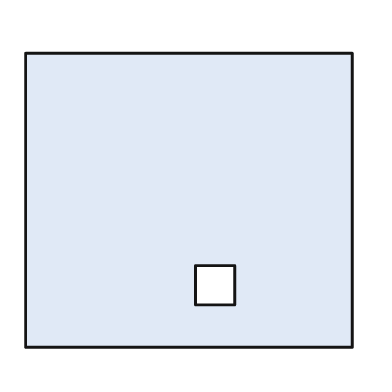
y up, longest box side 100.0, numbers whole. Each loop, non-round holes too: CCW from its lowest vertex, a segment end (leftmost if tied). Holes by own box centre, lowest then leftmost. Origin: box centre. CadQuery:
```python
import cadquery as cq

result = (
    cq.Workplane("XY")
    .moveTo(-50.0, -45.0)
    .lineTo(50.0, -45.0)
    .lineTo(50.0, 45.0)
    .lineTo(-50.0, 45.0)
    .close()
    .moveTo(2.0, -32.0)
    .lineTo(14.0, -32.0)
    .lineTo(14.0, -20.0)
    .lineTo(2.0, -20.0)
    .close()
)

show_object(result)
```